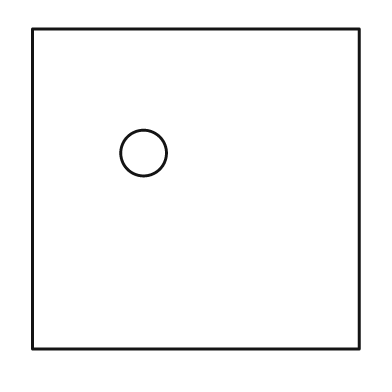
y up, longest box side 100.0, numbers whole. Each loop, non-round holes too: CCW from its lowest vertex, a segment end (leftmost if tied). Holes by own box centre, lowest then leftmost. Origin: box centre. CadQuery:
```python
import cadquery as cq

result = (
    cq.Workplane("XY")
    .moveTo(-50.0, -49.0)
    .lineTo(50.0, -49.0)
    .lineTo(50.0, 49.0)
    .lineTo(-50.0, 49.0)
    .close()
    .moveTo(-16.0, 11.0)
    .circle(7.0)
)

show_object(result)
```